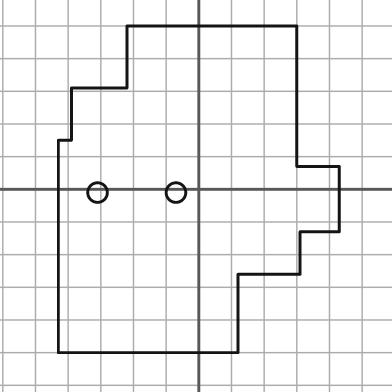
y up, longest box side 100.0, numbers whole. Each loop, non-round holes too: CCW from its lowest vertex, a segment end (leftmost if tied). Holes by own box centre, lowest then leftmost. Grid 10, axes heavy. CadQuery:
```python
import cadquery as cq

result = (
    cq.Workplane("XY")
    .moveTo(-43.0, -50.0)
    .lineTo(12.0, -50.0)
    .lineTo(12.0, -26.0)
    .lineTo(31.0, -26.0)
    .lineTo(31.0, -13.0)
    .lineTo(43.0, -13.0)
    .lineTo(43.0, 7.0)
    .lineTo(30.0, 7.0)
    .lineTo(30.0, 50.0)
    .lineTo(-22.0, 50.0)
    .lineTo(-22.0, 31.0)
    .lineTo(-39.0, 31.0)
    .lineTo(-39.0, 15.0)
    .lineTo(-43.0, 15.0)
    .close()
    .moveTo(-31.0, -1.0)
    .circle(3.0)
    .moveTo(-7.0, -1.0)
    .circle(3.0)
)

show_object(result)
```